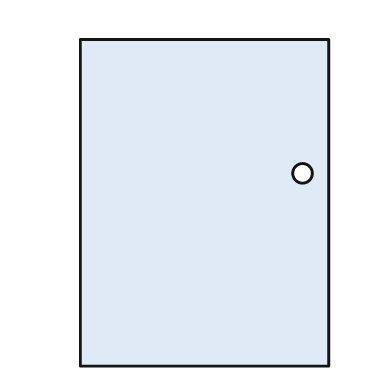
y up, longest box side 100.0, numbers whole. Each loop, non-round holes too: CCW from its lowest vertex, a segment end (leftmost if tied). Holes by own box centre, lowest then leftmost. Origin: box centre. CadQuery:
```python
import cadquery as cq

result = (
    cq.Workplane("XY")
    .moveTo(-38.0, -50.0)
    .lineTo(38.0, -50.0)
    .lineTo(38.0, 50.0)
    .lineTo(-38.0, 50.0)
    .close()
    .moveTo(30.0, 9.0)
    .circle(3.0)
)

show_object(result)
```